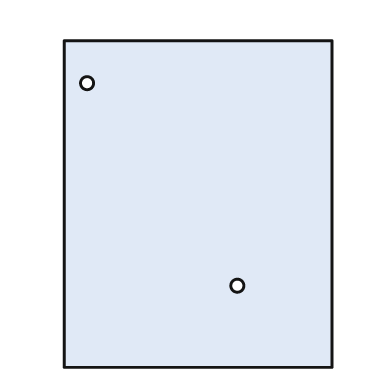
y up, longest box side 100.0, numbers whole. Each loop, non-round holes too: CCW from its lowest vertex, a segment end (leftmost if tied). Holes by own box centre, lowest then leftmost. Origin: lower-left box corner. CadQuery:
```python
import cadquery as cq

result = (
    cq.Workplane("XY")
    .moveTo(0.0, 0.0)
    .lineTo(82.0, 0.0)
    .lineTo(82.0, 100.0)
    .lineTo(0.0, 100.0)
    .close()
    .moveTo(53.0, 25.0)
    .circle(2.0)
    .moveTo(7.0, 87.0)
    .circle(2.0)
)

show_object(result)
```